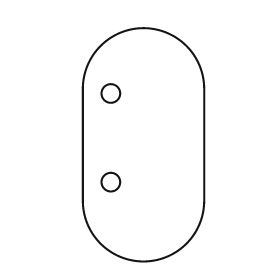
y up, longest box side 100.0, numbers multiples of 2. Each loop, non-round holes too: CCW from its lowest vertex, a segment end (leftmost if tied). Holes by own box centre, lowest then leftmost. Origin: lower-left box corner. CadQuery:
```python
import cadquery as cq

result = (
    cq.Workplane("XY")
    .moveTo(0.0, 26.0)
    .threePointArc((26.0, 0.0), (52.0, 26.0))
    .lineTo(52.0, 74.0)
    .threePointArc((26.0, 100.0), (0.0, 74.0))
    .close()
    .moveTo(12.0, 34.0)
    .circle(4.0)
    .moveTo(12.0, 72.0)
    .circle(4.0)
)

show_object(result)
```